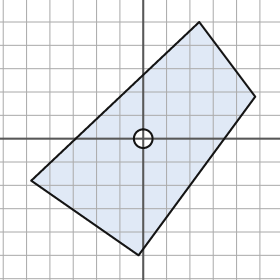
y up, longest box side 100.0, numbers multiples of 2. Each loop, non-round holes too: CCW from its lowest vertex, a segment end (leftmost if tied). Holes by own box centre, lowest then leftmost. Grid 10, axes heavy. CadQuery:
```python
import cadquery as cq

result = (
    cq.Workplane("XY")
    .moveTo(-2.0, -50.0)
    .lineTo(48.0, 18.0)
    .lineTo(24.0, 50.0)
    .lineTo(-48.0, -18.0)
    .close()
    .moveTo(0.0, 0.0)
    .circle(4.0)
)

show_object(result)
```